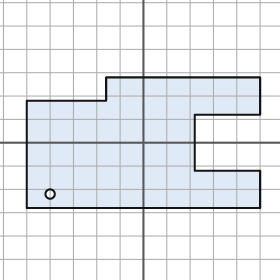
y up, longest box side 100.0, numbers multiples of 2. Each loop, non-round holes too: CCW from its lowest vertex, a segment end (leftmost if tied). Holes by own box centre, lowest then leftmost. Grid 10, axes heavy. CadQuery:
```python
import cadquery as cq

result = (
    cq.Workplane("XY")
    .moveTo(-50.0, -28.0)
    .lineTo(50.0, -28.0)
    .lineTo(50.0, -12.0)
    .lineTo(22.0, -12.0)
    .lineTo(22.0, 12.0)
    .lineTo(50.0, 12.0)
    .lineTo(50.0, 28.0)
    .lineTo(-16.0, 28.0)
    .lineTo(-16.0, 18.0)
    .lineTo(-50.0, 18.0)
    .close()
    .moveTo(-40.0, -22.0)
    .circle(2.0)
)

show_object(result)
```